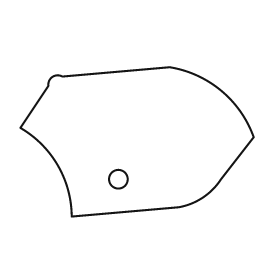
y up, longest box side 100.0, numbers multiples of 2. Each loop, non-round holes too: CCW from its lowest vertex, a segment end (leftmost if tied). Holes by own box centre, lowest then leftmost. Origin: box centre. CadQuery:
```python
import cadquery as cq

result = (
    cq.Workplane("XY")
    .moveTo(-28.0, -32.0)
    .lineTo(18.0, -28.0)
    .threePointArc((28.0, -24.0), (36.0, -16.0))
    .lineTo(50.0, 2.0)
    .threePointArc((36.0, 22.0), (14.0, 32.0))
    .lineTo(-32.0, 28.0)
    .threePointArc((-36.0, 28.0), (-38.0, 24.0))
    .lineTo(-50.0, 6.0)
    .threePointArc((-34.0, -10.0), (-28.0, -32.0))
    .close()
    .moveTo(-8.0, -16.0)
    .circle(4.0)
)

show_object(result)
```